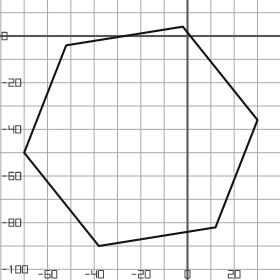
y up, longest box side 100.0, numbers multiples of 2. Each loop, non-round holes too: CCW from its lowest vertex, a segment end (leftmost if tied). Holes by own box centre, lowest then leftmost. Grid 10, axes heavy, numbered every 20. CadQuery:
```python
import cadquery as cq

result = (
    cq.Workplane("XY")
    .moveTo(-38.0, -90.0)
    .lineTo(12.0, -82.0)
    .lineTo(30.0, -36.0)
    .lineTo(-2.0, 4.0)
    .lineTo(-52.0, -4.0)
    .lineTo(-70.0, -50.0)
    .close()
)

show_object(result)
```